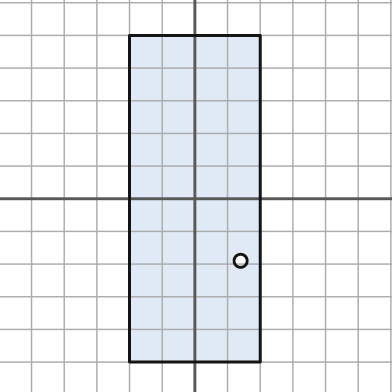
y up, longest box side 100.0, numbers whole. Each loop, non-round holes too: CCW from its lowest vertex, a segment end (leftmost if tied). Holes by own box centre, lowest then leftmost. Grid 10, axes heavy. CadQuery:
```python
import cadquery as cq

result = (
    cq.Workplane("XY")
    .moveTo(-20.0, -50.0)
    .lineTo(20.0, -50.0)
    .lineTo(20.0, 50.0)
    .lineTo(-20.0, 50.0)
    .close()
    .moveTo(14.0, -19.0)
    .circle(2.0)
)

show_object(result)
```